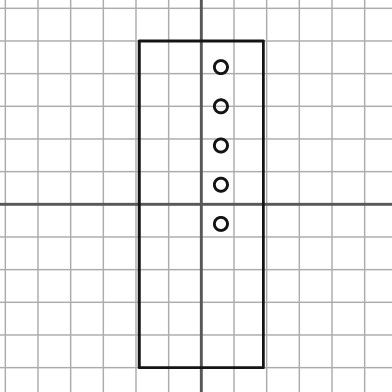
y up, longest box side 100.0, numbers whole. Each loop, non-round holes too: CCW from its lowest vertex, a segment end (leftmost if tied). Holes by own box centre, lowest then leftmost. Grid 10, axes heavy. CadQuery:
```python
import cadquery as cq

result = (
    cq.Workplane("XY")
    .moveTo(-19.0, -50.0)
    .lineTo(19.0, -50.0)
    .lineTo(19.0, 50.0)
    .lineTo(-19.0, 50.0)
    .close()
    .moveTo(6.0, -6.0)
    .circle(2.0)
    .moveTo(6.0, 6.0)
    .circle(2.0)
    .moveTo(6.0, 18.0)
    .circle(2.0)
    .moveTo(6.0, 30.0)
    .circle(2.0)
    .moveTo(6.0, 42.0)
    .circle(2.0)
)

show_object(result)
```